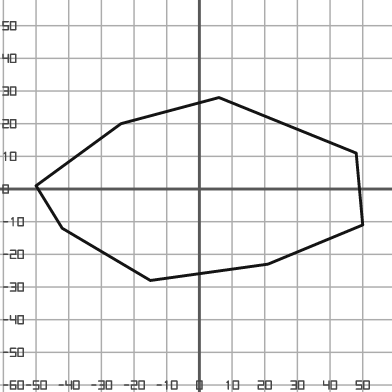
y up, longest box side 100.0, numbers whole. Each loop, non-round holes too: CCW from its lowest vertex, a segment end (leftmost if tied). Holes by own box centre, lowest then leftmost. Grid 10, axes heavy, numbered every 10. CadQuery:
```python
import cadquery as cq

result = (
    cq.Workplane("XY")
    .moveTo(-15.0, -28.0)
    .lineTo(21.0, -23.0)
    .lineTo(50.0, -11.0)
    .lineTo(48.0, 11.0)
    .lineTo(6.0, 28.0)
    .lineTo(-24.0, 20.0)
    .lineTo(-50.0, 1.0)
    .lineTo(-42.0, -12.0)
    .close()
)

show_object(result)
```